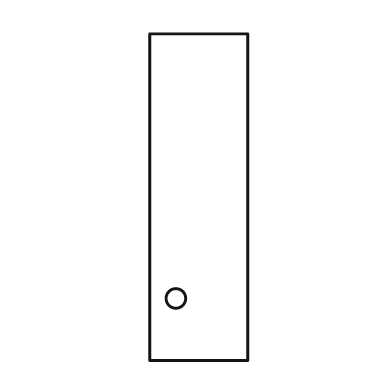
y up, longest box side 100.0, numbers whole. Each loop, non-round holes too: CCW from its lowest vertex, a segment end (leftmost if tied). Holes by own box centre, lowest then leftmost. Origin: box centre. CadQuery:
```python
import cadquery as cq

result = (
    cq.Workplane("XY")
    .moveTo(-15.0, -50.0)
    .lineTo(15.0, -50.0)
    .lineTo(15.0, 50.0)
    .lineTo(-15.0, 50.0)
    .close()
    .moveTo(-7.0, -31.0)
    .circle(3.0)
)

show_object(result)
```